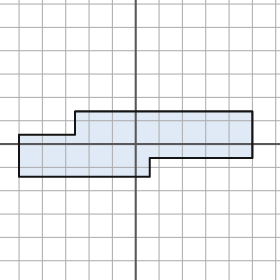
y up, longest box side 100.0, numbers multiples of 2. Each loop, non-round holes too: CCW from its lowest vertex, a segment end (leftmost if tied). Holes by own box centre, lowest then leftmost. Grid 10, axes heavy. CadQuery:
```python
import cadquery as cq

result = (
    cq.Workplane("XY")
    .moveTo(-50.0, -14.0)
    .lineTo(6.0, -14.0)
    .lineTo(6.0, -6.0)
    .lineTo(50.0, -6.0)
    .lineTo(50.0, 14.0)
    .lineTo(-26.0, 14.0)
    .lineTo(-26.0, 4.0)
    .lineTo(-50.0, 4.0)
    .close()
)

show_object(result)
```